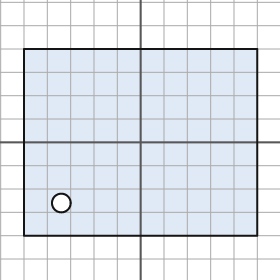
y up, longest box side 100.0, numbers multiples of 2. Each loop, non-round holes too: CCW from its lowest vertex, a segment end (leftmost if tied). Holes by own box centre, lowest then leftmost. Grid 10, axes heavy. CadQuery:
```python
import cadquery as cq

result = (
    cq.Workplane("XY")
    .moveTo(-50.0, -40.0)
    .lineTo(50.0, -40.0)
    .lineTo(50.0, 40.0)
    .lineTo(-50.0, 40.0)
    .close()
    .moveTo(-34.0, -26.0)
    .circle(4.0)
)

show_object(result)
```